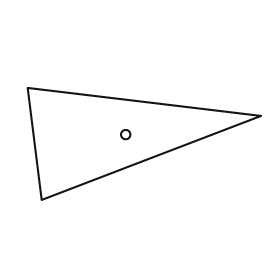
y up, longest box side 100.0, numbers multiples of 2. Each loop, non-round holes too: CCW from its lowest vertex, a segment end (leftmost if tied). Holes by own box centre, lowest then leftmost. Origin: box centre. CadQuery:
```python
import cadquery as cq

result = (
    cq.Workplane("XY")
    .moveTo(-44.0, -24.0)
    .lineTo(50.0, 12.0)
    .lineTo(-50.0, 24.0)
    .close()
    .moveTo(-8.0, 4.0)
    .circle(2.0)
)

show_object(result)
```